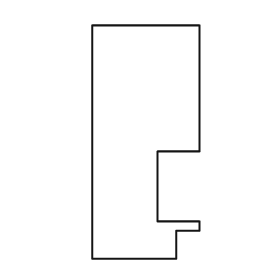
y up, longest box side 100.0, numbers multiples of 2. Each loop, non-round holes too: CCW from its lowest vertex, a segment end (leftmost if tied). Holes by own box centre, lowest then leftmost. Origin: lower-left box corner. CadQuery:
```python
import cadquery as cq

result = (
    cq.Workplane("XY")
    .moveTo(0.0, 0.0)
    .lineTo(36.0, 0.0)
    .lineTo(36.0, 12.0)
    .lineTo(46.0, 12.0)
    .lineTo(46.0, 16.0)
    .lineTo(28.0, 16.0)
    .lineTo(28.0, 46.0)
    .lineTo(46.0, 46.0)
    .lineTo(46.0, 100.0)
    .lineTo(0.0, 100.0)
    .close()
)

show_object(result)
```